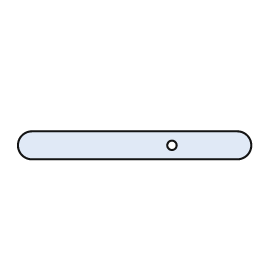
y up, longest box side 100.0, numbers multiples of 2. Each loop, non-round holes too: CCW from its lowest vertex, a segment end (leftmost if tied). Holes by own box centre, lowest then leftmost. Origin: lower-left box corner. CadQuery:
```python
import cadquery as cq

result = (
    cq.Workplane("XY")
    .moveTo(6.0, 0.0)
    .lineTo(94.0, 0.0)
    .threePointArc((100.0, 6.0), (94.0, 12.0))
    .lineTo(6.0, 12.0)
    .threePointArc((0.0, 6.0), (6.0, 0.0))
    .close()
    .moveTo(66.0, 6.0)
    .circle(2.0)
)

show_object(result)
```